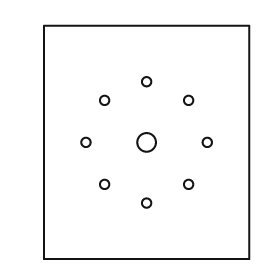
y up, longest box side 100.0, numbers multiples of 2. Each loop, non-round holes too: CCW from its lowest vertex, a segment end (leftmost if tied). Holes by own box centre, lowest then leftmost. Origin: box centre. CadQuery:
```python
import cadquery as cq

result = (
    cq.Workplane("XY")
    .moveTo(-44.0, -50.0)
    .lineTo(44.0, -50.0)
    .lineTo(44.0, 50.0)
    .lineTo(-44.0, 50.0)
    .close()
    .moveTo(0.0, -26.0)
    .circle(2.0)
    .moveTo(-18.0, -18.0)
    .circle(2.0)
    .moveTo(18.0, -18.0)
    .circle(2.0)
    .moveTo(-26.0, 0.0)
    .circle(2.0)
    .moveTo(0.0, 0.0)
    .circle(4.0)
    .moveTo(26.0, 0.0)
    .circle(2.0)
    .moveTo(-18.0, 18.0)
    .circle(2.0)
    .moveTo(18.0, 18.0)
    .circle(2.0)
    .moveTo(0.0, 26.0)
    .circle(2.0)
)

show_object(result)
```